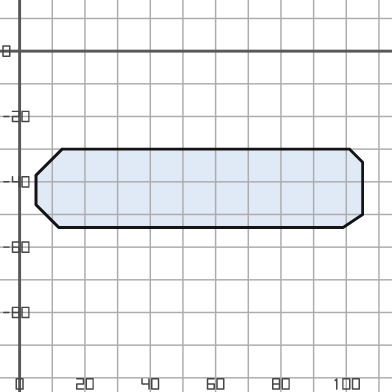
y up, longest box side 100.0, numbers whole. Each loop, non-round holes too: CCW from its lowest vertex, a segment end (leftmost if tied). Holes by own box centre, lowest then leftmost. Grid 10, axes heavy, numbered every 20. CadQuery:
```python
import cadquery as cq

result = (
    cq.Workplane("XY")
    .moveTo(12.0, -54.0)
    .lineTo(99.0, -54.0)
    .lineTo(105.0, -50.0)
    .lineTo(105.0, -34.0)
    .lineTo(101.0, -30.0)
    .lineTo(13.0, -30.0)
    .lineTo(5.0, -38.0)
    .lineTo(5.0, -47.0)
    .close()
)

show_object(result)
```